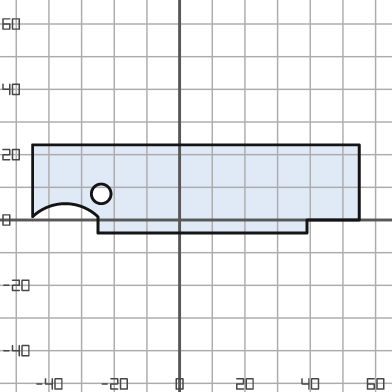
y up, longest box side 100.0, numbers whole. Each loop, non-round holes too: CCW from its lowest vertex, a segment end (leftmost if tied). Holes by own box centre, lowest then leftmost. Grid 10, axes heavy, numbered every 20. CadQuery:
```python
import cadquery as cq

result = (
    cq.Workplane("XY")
    .moveTo(-25.0, -4.0)
    .lineTo(39.0, -4.0)
    .lineTo(39.0, 0.0)
    .lineTo(55.0, 0.0)
    .lineTo(55.0, 23.0)
    .lineTo(-45.0, 23.0)
    .lineTo(-45.0, 1.0)
    .threePointArc((-35.0, 5.0), (-25.0, 1.0))
    .close()
    .moveTo(-24.0, 8.0)
    .circle(3.0)
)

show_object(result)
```